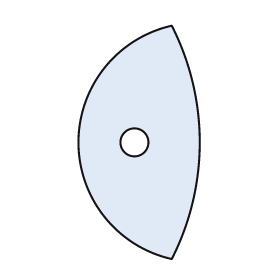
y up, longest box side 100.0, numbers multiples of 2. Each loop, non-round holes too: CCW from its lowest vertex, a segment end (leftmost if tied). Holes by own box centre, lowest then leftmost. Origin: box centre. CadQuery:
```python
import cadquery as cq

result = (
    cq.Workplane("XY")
    .moveTo(14.0, -50.0)
    .threePointArc((26.0, 0.0), (14.0, 50.0))
    .threePointArc((-26.0, 0.0), (14.0, -50.0))
    .close()
    .moveTo(-2.0, 0.0)
    .circle(6.0)
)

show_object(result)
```